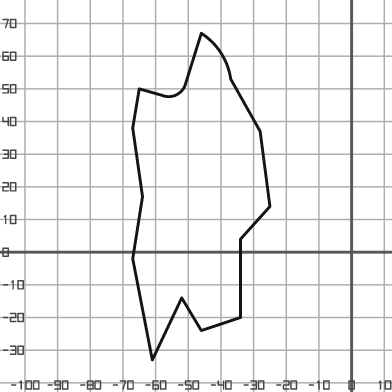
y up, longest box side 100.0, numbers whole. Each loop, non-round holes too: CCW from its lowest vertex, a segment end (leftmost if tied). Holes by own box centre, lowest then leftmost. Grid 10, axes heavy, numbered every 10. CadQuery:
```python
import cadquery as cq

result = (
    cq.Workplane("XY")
    .moveTo(-61.0, -33.0)
    .lineTo(-52.0, -14.0)
    .lineTo(-46.0, -24.0)
    .lineTo(-34.0, -20.0)
    .lineTo(-34.0, 4.0)
    .lineTo(-25.0, 14.0)
    .lineTo(-28.0, 37.0)
    .lineTo(-37.0, 53.0)
    .threePointArc((-40.0, 61.0), (-46.0, 67.0))
    .lineTo(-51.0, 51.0)
    .threePointArc((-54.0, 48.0), (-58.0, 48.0))
    .lineTo(-65.0, 50.0)
    .lineTo(-67.0, 38.0)
    .lineTo(-64.0, 17.0)
    .lineTo(-67.0, -2.0)
    .close()
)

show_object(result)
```